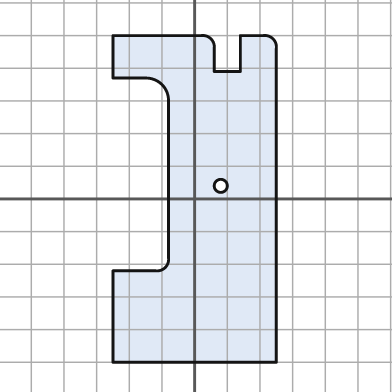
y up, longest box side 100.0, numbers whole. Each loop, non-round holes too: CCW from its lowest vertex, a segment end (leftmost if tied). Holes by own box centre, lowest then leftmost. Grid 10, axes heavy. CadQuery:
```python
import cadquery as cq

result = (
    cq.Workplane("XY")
    .moveTo(-25.0, -50.0)
    .lineTo(25.0, -50.0)
    .lineTo(25.0, 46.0)
    .threePointArc((24.0, 49.0), (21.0, 50.0))
    .lineTo(14.0, 50.0)
    .lineTo(14.0, 39.0)
    .lineTo(6.0, 39.0)
    .lineTo(6.0, 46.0)
    .threePointArc((5.0, 49.0), (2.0, 50.0))
    .lineTo(-25.0, 50.0)
    .lineTo(-25.0, 37.0)
    .lineTo(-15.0, 37.0)
    .threePointArc((-10.0, 35.0), (-8.0, 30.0))
    .lineTo(-8.0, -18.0)
    .threePointArc((-9.0, -21.0), (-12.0, -22.0))
    .lineTo(-25.0, -22.0)
    .close()
    .moveTo(8.0, 4.0)
    .circle(2.0)
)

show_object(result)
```